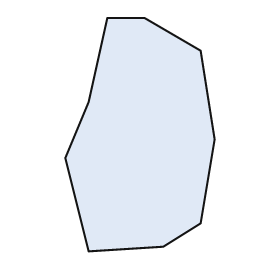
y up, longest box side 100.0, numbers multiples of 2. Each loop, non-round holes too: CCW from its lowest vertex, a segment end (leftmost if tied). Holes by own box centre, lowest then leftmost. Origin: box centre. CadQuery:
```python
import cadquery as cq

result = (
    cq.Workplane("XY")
    .moveTo(-22.0, -50.0)
    .lineTo(10.0, -48.0)
    .lineTo(26.0, -38.0)
    .lineTo(32.0, -2.0)
    .lineTo(26.0, 36.0)
    .lineTo(2.0, 50.0)
    .lineTo(-14.0, 50.0)
    .lineTo(-22.0, 14.0)
    .lineTo(-32.0, -10.0)
    .close()
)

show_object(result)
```